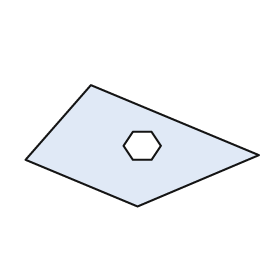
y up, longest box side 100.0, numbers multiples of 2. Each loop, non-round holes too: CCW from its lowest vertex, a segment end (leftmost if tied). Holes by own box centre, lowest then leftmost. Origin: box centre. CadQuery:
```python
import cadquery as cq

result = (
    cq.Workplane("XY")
    .moveTo(-2.0, -26.0)
    .lineTo(50.0, -4.0)
    .lineTo(-22.0, 26.0)
    .lineTo(-50.0, -6.0)
    .close()
    .moveTo(-4.0, -6.0)
    .lineTo(4.0, -6.0)
    .lineTo(8.0, 0.0)
    .lineTo(4.0, 6.0)
    .lineTo(-4.0, 6.0)
    .lineTo(-8.0, 0.0)
    .close()
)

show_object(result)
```